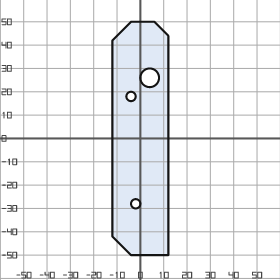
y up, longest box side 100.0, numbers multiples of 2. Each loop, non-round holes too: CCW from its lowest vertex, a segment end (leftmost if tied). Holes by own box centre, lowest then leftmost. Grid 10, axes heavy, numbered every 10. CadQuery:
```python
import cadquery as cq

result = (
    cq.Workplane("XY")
    .moveTo(-4.0, -50.0)
    .lineTo(12.0, -50.0)
    .lineTo(12.0, 44.0)
    .lineTo(6.0, 50.0)
    .lineTo(-4.0, 50.0)
    .lineTo(-12.0, 42.0)
    .lineTo(-12.0, -42.0)
    .close()
    .moveTo(-2.0, -28.0)
    .circle(2.0)
    .moveTo(-4.0, 18.0)
    .circle(2.0)
    .moveTo(4.0, 26.0)
    .circle(4.0)
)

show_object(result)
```